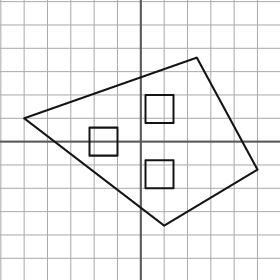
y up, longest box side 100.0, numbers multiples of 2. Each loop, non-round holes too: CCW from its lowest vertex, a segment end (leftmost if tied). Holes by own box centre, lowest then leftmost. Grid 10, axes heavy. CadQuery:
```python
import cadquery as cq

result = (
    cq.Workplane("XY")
    .moveTo(10.0, -36.0)
    .lineTo(50.0, -12.0)
    .lineTo(24.0, 36.0)
    .lineTo(-50.0, 10.0)
    .close()
    .moveTo(2.0, -20.0)
    .lineTo(14.0, -20.0)
    .lineTo(14.0, -8.0)
    .lineTo(2.0, -8.0)
    .close()
    .moveTo(-22.0, -6.0)
    .lineTo(-10.0, -6.0)
    .lineTo(-10.0, 6.0)
    .lineTo(-22.0, 6.0)
    .close()
    .moveTo(2.0, 8.0)
    .lineTo(14.0, 8.0)
    .lineTo(14.0, 20.0)
    .lineTo(2.0, 20.0)
    .close()
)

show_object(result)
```